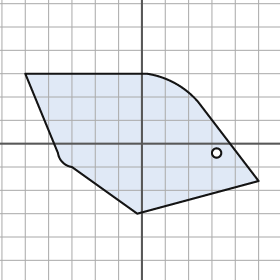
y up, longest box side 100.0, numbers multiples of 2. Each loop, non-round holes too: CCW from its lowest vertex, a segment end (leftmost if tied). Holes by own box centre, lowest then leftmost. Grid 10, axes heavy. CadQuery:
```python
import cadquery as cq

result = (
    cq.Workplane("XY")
    .moveTo(-2.0, -30.0)
    .lineTo(50.0, -16.0)
    .lineTo(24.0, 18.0)
    .threePointArc((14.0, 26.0), (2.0, 30.0))
    .lineTo(-50.0, 30.0)
    .lineTo(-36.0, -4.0)
    .threePointArc((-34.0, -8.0), (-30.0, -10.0))
    .close()
    .moveTo(32.0, -4.0)
    .circle(2.0)
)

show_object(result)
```